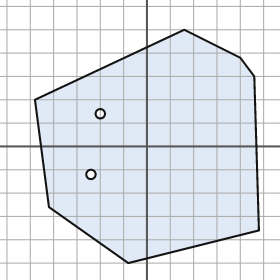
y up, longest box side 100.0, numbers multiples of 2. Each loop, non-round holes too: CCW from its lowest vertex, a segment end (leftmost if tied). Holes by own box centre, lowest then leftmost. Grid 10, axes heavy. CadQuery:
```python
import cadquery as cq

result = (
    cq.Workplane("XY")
    .moveTo(-8.0, -50.0)
    .lineTo(48.0, -36.0)
    .lineTo(46.0, 30.0)
    .lineTo(40.0, 38.0)
    .lineTo(16.0, 50.0)
    .lineTo(-48.0, 20.0)
    .lineTo(-42.0, -26.0)
    .close()
    .moveTo(-24.0, -12.0)
    .circle(2.0)
    .moveTo(-20.0, 14.0)
    .circle(2.0)
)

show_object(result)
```